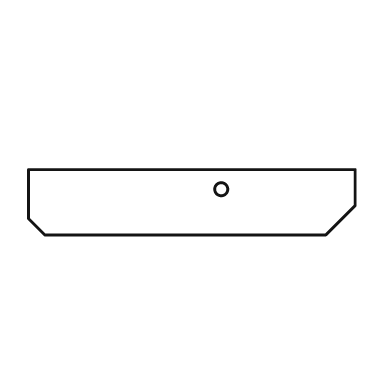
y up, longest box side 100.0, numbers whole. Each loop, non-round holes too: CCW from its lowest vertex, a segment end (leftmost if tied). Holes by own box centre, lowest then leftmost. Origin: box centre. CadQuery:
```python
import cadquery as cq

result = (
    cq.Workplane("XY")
    .moveTo(-45.0, -10.0)
    .lineTo(41.0, -10.0)
    .lineTo(50.0, -1.0)
    .lineTo(50.0, 10.0)
    .lineTo(-50.0, 10.0)
    .lineTo(-50.0, -5.0)
    .close()
    .moveTo(9.0, 4.0)
    .circle(2.0)
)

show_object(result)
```